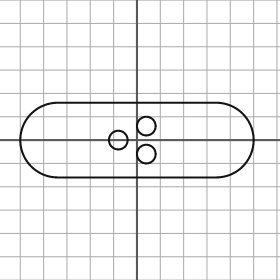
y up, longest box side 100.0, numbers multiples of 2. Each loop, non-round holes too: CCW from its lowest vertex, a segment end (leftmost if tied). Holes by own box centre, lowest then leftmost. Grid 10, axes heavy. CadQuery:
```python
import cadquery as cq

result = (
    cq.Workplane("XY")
    .moveTo(-34.0, -16.0)
    .lineTo(34.0, -16.0)
    .threePointArc((50.0, 0.0), (34.0, 16.0))
    .lineTo(-34.0, 16.0)
    .threePointArc((-50.0, 0.0), (-34.0, -16.0))
    .close()
    .moveTo(4.0, -6.0)
    .circle(4.0)
    .moveTo(-8.0, 0.0)
    .circle(4.0)
    .moveTo(4.0, 6.0)
    .circle(4.0)
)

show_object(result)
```